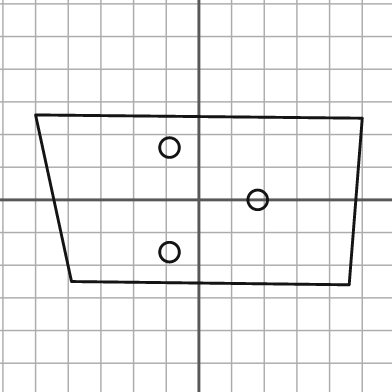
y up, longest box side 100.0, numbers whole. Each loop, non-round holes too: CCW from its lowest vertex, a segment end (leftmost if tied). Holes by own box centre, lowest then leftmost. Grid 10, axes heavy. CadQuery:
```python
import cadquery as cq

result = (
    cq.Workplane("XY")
    .moveTo(46.0, -26.0)
    .lineTo(50.0, 25.0)
    .lineTo(-50.0, 26.0)
    .lineTo(-39.0, -25.0)
    .close()
    .moveTo(-9.0, -16.0)
    .circle(3.0)
    .moveTo(18.0, 0.0)
    .circle(3.0)
    .moveTo(-9.0, 16.0)
    .circle(3.0)
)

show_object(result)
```